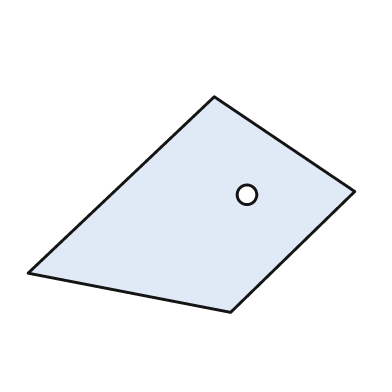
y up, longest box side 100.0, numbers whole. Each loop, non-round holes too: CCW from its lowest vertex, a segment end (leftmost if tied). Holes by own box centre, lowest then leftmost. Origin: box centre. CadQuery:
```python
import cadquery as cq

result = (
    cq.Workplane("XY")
    .moveTo(12.0, -33.0)
    .lineTo(50.0, 4.0)
    .lineTo(7.0, 33.0)
    .lineTo(-50.0, -21.0)
    .close()
    .moveTo(17.0, 3.0)
    .circle(3.0)
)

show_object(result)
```